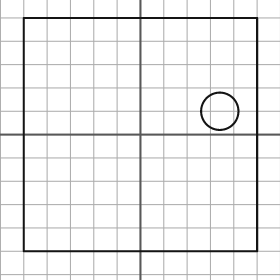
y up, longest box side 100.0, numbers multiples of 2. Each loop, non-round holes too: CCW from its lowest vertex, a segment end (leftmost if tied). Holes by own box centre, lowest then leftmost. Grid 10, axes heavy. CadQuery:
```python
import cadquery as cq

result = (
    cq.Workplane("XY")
    .moveTo(-50.0, -50.0)
    .lineTo(50.0, -50.0)
    .lineTo(50.0, 50.0)
    .lineTo(-50.0, 50.0)
    .close()
    .moveTo(34.0, 10.0)
    .circle(8.0)
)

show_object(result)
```